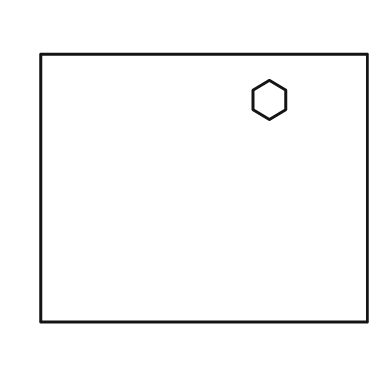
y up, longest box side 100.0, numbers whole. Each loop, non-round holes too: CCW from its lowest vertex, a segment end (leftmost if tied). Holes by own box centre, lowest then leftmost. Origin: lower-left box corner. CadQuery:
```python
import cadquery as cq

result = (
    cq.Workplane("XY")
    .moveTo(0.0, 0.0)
    .lineTo(100.0, 0.0)
    .lineTo(100.0, 82.0)
    .lineTo(0.0, 82.0)
    .close()
    .moveTo(70.0, 62.0)
    .lineTo(75.0, 65.0)
    .lineTo(75.0, 71.0)
    .lineTo(70.0, 74.0)
    .lineTo(65.0, 71.0)
    .lineTo(65.0, 65.0)
    .close()
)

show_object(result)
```